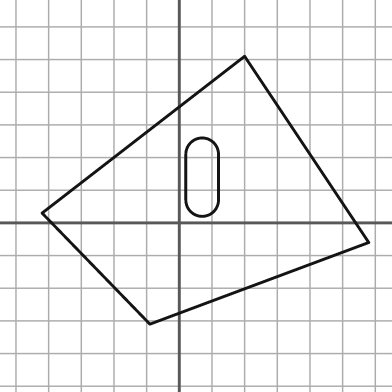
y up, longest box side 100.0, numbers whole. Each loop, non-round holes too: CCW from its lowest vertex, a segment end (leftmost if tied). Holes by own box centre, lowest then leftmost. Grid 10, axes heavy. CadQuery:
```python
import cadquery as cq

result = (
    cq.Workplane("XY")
    .moveTo(-9.0, -31.0)
    .lineTo(58.0, -6.0)
    .lineTo(20.0, 51.0)
    .lineTo(-42.0, 3.0)
    .close()
    .moveTo(2.0, 7.0)
    .threePointArc((7.0, 2.0), (12.0, 7.0))
    .lineTo(12.0, 21.0)
    .threePointArc((7.0, 26.0), (2.0, 21.0))
    .close()
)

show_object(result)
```